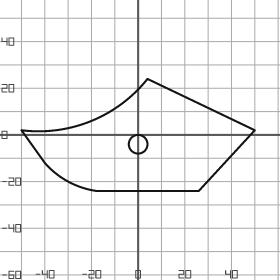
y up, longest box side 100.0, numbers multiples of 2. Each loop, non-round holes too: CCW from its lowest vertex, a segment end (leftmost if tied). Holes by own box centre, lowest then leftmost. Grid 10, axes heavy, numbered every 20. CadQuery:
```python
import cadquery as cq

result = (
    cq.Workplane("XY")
    .moveTo(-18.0, -24.0)
    .lineTo(26.0, -24.0)
    .lineTo(50.0, 2.0)
    .lineTo(4.0, 24.0)
    .threePointArc((-20.0, 6.0), (-50.0, 2.0))
    .lineTo(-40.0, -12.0)
    .threePointArc((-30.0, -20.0), (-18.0, -24.0))
    .close()
    .moveTo(0.0, -4.0)
    .circle(4.0)
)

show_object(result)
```